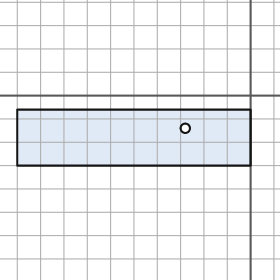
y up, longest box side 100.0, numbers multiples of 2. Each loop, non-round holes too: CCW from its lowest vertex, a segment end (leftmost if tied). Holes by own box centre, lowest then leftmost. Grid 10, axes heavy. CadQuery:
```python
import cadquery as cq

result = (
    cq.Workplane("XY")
    .moveTo(-100.0, -30.0)
    .lineTo(0.0, -30.0)
    .lineTo(0.0, -6.0)
    .lineTo(-100.0, -6.0)
    .close()
    .moveTo(-28.0, -14.0)
    .circle(2.0)
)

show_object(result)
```